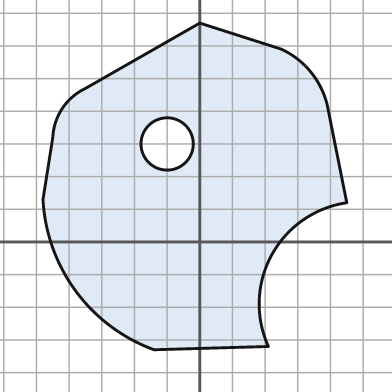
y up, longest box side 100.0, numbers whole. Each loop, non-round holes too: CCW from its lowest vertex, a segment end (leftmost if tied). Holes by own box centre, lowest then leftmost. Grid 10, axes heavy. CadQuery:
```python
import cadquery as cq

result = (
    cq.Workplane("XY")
    .moveTo(-14.0, -33.0)
    .lineTo(21.0, -32.0)
    .threePointArc((22.0, -4.0), (45.0, 12.0))
    .lineTo(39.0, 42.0)
    .threePointArc((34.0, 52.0), (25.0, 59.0))
    .lineTo(0.0, 67.0)
    .lineTo(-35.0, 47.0)
    .threePointArc((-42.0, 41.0), (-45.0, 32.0))
    .lineTo(-48.0, 13.0)
    .threePointArc((-38.0, -15.0), (-14.0, -33.0))
    .close()
    .moveTo(-10.0, 30.0)
    .circle(8.0)
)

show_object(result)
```